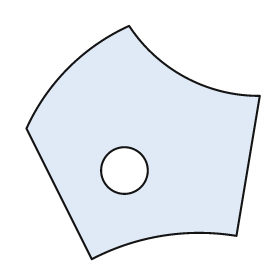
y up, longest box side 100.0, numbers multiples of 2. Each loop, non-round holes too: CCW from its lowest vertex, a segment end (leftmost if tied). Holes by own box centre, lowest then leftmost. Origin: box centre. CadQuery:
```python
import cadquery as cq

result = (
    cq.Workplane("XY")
    .moveTo(-22.0, -50.0)
    .threePointArc((8.0, -40.0), (40.0, -40.0))
    .lineTo(50.0, 20.0)
    .threePointArc((18.0, 28.0), (-6.0, 50.0))
    .threePointArc((-32.0, 32.0), (-50.0, 6.0))
    .close()
    .moveTo(-8.0, -12.0)
    .circle(10.0)
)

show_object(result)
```